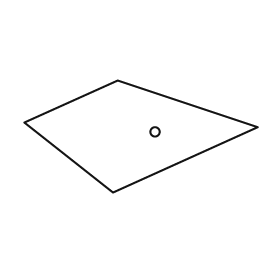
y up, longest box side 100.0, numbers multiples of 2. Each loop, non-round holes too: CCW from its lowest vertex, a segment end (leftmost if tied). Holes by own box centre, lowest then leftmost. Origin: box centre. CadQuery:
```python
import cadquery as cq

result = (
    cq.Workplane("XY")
    .moveTo(-12.0, -24.0)
    .lineTo(50.0, 4.0)
    .lineTo(-10.0, 24.0)
    .lineTo(-50.0, 6.0)
    .close()
    .moveTo(6.0, 2.0)
    .circle(2.0)
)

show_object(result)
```